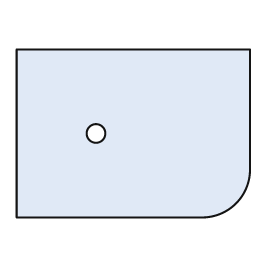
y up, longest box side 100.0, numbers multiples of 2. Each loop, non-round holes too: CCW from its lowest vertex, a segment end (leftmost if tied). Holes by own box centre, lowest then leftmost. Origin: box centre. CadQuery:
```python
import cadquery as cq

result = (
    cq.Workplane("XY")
    .moveTo(-50.0, -36.0)
    .lineTo(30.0, -36.0)
    .threePointArc((44.0, -30.0), (50.0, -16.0))
    .lineTo(50.0, 36.0)
    .lineTo(-50.0, 36.0)
    .close()
    .moveTo(-16.0, 0.0)
    .circle(4.0)
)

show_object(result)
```